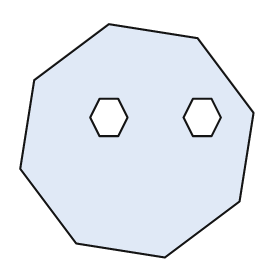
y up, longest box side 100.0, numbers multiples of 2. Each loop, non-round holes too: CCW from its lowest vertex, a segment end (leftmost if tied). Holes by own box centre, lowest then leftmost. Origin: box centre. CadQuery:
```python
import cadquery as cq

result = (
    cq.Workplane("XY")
    .moveTo(12.0, -50.0)
    .lineTo(44.0, -26.0)
    .lineTo(50.0, 12.0)
    .lineTo(26.0, 44.0)
    .lineTo(-12.0, 50.0)
    .lineTo(-44.0, 26.0)
    .lineTo(-50.0, -12.0)
    .lineTo(-26.0, -44.0)
    .close()
    .moveTo(-16.0, 2.0)
    .lineTo(-8.0, 2.0)
    .lineTo(-4.0, 10.0)
    .lineTo(-8.0, 18.0)
    .lineTo(-16.0, 18.0)
    .lineTo(-20.0, 10.0)
    .close()
    .moveTo(24.0, 2.0)
    .lineTo(32.0, 2.0)
    .lineTo(36.0, 10.0)
    .lineTo(32.0, 18.0)
    .lineTo(24.0, 18.0)
    .lineTo(20.0, 10.0)
    .close()
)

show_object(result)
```